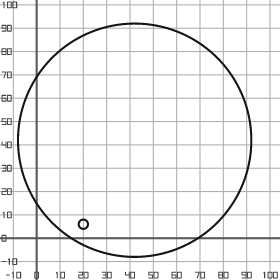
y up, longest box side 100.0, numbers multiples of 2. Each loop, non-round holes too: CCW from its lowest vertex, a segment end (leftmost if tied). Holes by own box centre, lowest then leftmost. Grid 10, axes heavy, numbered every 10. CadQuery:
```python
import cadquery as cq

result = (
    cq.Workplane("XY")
    .moveTo(42.0, 42.0)
    .circle(50.0)
    .moveTo(20.0, 6.0)
    .circle(2.0)
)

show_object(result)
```